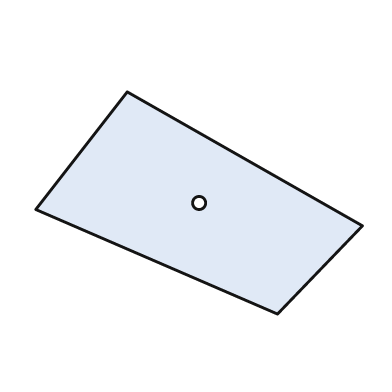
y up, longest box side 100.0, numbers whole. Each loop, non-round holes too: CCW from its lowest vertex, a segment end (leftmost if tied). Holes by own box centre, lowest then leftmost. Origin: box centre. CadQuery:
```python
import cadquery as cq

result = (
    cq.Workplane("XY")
    .moveTo(24.0, -34.0)
    .lineTo(50.0, -7.0)
    .lineTo(-22.0, 34.0)
    .lineTo(-50.0, -2.0)
    .close()
    .moveTo(0.0, 0.0)
    .circle(2.0)
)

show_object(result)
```